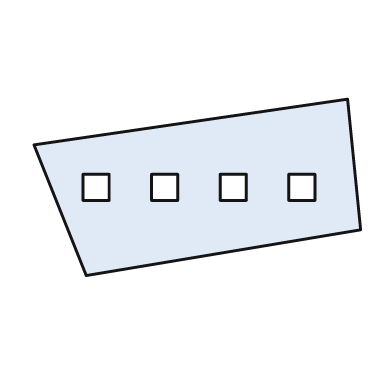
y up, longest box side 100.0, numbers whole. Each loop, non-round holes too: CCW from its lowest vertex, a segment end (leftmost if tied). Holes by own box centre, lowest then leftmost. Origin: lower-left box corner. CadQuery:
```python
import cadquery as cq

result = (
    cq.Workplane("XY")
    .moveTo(16.0, 0.0)
    .lineTo(100.0, 14.0)
    .lineTo(96.0, 54.0)
    .lineTo(0.0, 40.0)
    .close()
    .moveTo(15.0, 23.0)
    .lineTo(23.0, 23.0)
    .lineTo(23.0, 31.0)
    .lineTo(15.0, 31.0)
    .close()
    .moveTo(36.0, 23.0)
    .lineTo(44.0, 23.0)
    .lineTo(44.0, 31.0)
    .lineTo(36.0, 31.0)
    .close()
    .moveTo(57.0, 23.0)
    .lineTo(65.0, 23.0)
    .lineTo(65.0, 31.0)
    .lineTo(57.0, 31.0)
    .close()
    .moveTo(78.0, 23.0)
    .lineTo(86.0, 23.0)
    .lineTo(86.0, 31.0)
    .lineTo(78.0, 31.0)
    .close()
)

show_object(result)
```